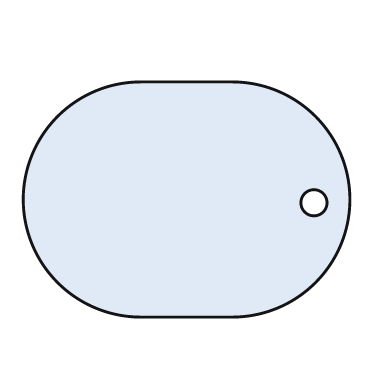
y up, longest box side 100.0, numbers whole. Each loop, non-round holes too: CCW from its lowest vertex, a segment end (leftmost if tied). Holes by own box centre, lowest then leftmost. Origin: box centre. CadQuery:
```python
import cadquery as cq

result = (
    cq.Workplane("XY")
    .moveTo(-14.0, -36.0)
    .lineTo(14.0, -36.0)
    .threePointArc((50.0, 0.0), (14.0, 36.0))
    .lineTo(-14.0, 36.0)
    .threePointArc((-50.0, 0.0), (-14.0, -36.0))
    .close()
    .moveTo(39.0, -1.0)
    .circle(4.0)
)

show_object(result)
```